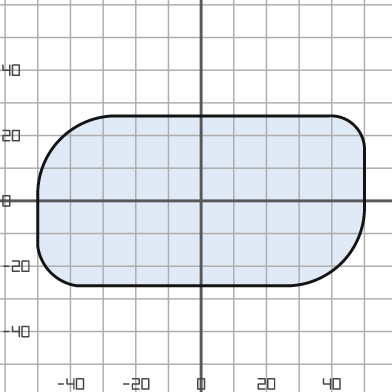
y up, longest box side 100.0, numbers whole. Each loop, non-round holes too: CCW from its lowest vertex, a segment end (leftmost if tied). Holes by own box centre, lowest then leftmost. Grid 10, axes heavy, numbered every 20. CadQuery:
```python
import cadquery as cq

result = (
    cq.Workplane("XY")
    .moveTo(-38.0, -26.0)
    .lineTo(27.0, -26.0)
    .threePointArc((43.0, -19.0), (50.0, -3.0))
    .lineTo(50.0, 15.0)
    .threePointArc((47.0, 23.0), (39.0, 26.0))
    .lineTo(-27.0, 26.0)
    .threePointArc((-43.0, 19.0), (-50.0, 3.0))
    .lineTo(-50.0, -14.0)
    .threePointArc((-46.0, -22.0), (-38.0, -26.0))
    .close()
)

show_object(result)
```